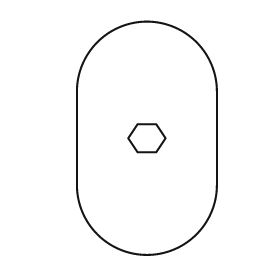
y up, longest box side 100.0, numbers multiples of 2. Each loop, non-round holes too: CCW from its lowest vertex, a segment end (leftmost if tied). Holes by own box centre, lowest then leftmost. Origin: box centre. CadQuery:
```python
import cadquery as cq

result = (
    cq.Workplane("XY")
    .moveTo(-30.0, -20.0)
    .threePointArc((0.0, -50.0), (30.0, -20.0))
    .lineTo(30.0, 20.0)
    .threePointArc((0.0, 50.0), (-30.0, 20.0))
    .close()
    .moveTo(-4.0, -6.0)
    .lineTo(4.0, -6.0)
    .lineTo(8.0, 0.0)
    .lineTo(4.0, 6.0)
    .lineTo(-4.0, 6.0)
    .lineTo(-8.0, 0.0)
    .close()
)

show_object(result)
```